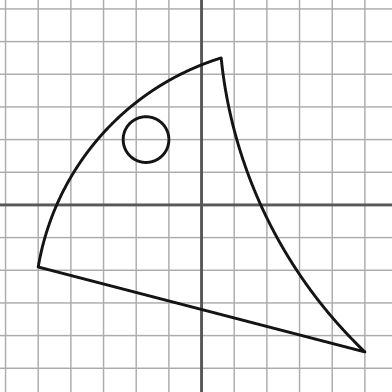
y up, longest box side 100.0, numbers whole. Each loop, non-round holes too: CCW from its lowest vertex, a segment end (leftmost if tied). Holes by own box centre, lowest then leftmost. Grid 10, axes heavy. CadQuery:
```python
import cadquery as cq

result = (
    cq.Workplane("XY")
    .moveTo(50.0, -45.0)
    .threePointArc((20.0, -4.0), (6.0, 45.0))
    .threePointArc((-31.0, 21.0), (-50.0, -19.0))
    .close()
    .moveTo(-17.0, 20.0)
    .circle(7.0)
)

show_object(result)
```